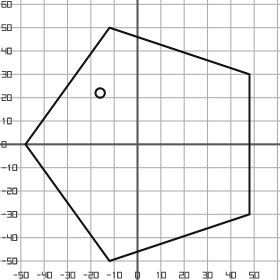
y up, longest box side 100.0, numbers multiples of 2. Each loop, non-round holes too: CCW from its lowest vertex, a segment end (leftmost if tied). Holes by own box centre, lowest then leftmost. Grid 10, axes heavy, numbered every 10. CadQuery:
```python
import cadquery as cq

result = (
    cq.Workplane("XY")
    .moveTo(-12.0, -50.0)
    .lineTo(48.0, -30.0)
    .lineTo(48.0, 30.0)
    .lineTo(-12.0, 50.0)
    .lineTo(-48.0, 0.0)
    .close()
    .moveTo(-16.0, 22.0)
    .circle(2.0)
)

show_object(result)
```